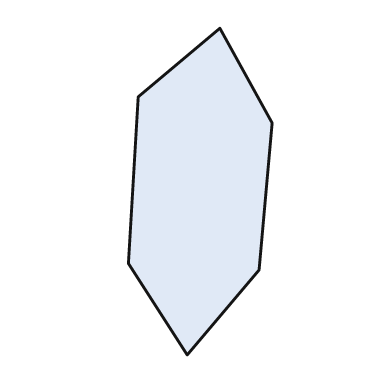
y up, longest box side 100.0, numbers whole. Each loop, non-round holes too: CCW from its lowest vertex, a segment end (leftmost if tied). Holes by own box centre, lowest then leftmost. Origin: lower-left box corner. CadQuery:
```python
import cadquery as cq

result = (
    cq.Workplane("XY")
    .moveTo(18.0, 0.0)
    .lineTo(40.0, 26.0)
    .lineTo(44.0, 71.0)
    .lineTo(28.0, 100.0)
    .lineTo(3.0, 79.0)
    .lineTo(0.0, 28.0)
    .close()
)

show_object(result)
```